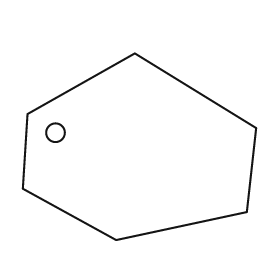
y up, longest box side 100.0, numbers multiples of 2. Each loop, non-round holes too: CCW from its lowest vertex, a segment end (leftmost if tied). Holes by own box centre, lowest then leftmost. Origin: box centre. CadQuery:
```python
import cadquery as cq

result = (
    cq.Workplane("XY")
    .moveTo(-10.0, -40.0)
    .lineTo(46.0, -28.0)
    .lineTo(50.0, 8.0)
    .lineTo(-2.0, 40.0)
    .lineTo(-48.0, 14.0)
    .lineTo(-50.0, -18.0)
    .close()
    .moveTo(-36.0, 6.0)
    .circle(4.0)
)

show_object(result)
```